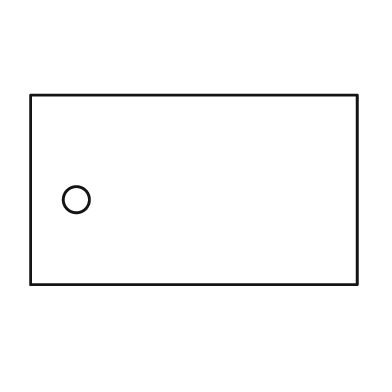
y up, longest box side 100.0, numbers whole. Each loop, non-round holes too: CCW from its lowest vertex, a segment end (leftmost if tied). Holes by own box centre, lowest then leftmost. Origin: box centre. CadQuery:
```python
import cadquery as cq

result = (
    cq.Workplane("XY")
    .moveTo(-50.0, -29.0)
    .lineTo(50.0, -29.0)
    .lineTo(50.0, 29.0)
    .lineTo(-50.0, 29.0)
    .close()
    .moveTo(-36.0, -3.0)
    .circle(4.0)
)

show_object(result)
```